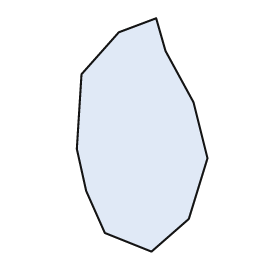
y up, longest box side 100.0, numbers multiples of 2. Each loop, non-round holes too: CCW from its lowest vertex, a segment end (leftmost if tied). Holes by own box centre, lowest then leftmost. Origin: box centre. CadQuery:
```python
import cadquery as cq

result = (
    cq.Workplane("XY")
    .moveTo(4.0, -50.0)
    .lineTo(20.0, -36.0)
    .lineTo(28.0, -10.0)
    .lineTo(22.0, 14.0)
    .lineTo(10.0, 36.0)
    .lineTo(6.0, 50.0)
    .lineTo(-10.0, 44.0)
    .lineTo(-26.0, 26.0)
    .lineTo(-28.0, -6.0)
    .lineTo(-24.0, -24.0)
    .lineTo(-16.0, -42.0)
    .close()
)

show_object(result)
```